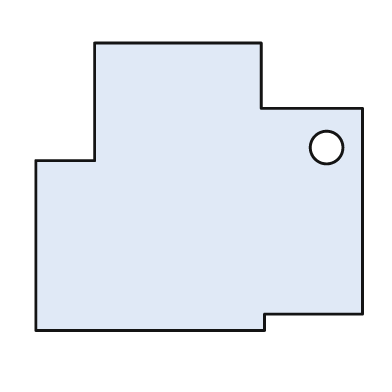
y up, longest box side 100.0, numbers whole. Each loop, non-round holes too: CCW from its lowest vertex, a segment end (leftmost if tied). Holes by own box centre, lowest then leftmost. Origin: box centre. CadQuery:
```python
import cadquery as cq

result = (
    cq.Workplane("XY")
    .moveTo(-50.0, -44.0)
    .lineTo(20.0, -44.0)
    .lineTo(20.0, -39.0)
    .lineTo(50.0, -39.0)
    .lineTo(50.0, 24.0)
    .lineTo(19.0, 24.0)
    .lineTo(19.0, 44.0)
    .lineTo(-32.0, 44.0)
    .lineTo(-32.0, 8.0)
    .lineTo(-50.0, 8.0)
    .close()
    .moveTo(39.0, 12.0)
    .circle(5.0)
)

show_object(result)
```